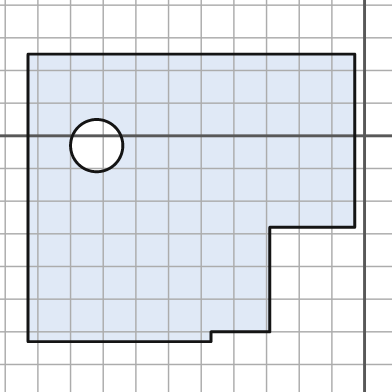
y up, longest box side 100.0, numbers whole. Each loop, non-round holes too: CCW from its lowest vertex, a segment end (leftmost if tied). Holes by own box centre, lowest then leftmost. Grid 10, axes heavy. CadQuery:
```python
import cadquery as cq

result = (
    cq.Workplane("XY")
    .moveTo(-103.0, -63.0)
    .lineTo(-47.0, -63.0)
    .lineTo(-47.0, -60.0)
    .lineTo(-29.0, -60.0)
    .lineTo(-29.0, -28.0)
    .lineTo(-3.0, -28.0)
    .lineTo(-3.0, 25.0)
    .lineTo(-103.0, 25.0)
    .close()
    .moveTo(-82.0, -3.0)
    .circle(8.0)
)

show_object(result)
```